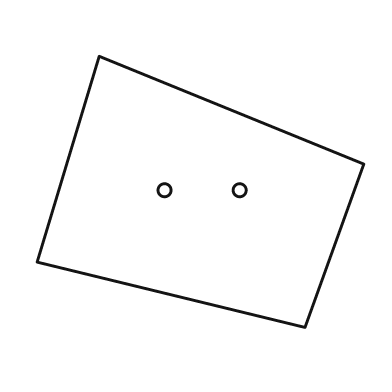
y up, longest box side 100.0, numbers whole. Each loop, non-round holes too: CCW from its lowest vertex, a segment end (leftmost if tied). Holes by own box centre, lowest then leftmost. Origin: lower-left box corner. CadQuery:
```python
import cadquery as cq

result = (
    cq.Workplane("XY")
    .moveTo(82.0, 0.0)
    .lineTo(100.0, 50.0)
    .lineTo(19.0, 83.0)
    .lineTo(0.0, 20.0)
    .close()
    .moveTo(39.0, 42.0)
    .circle(2.0)
    .moveTo(62.0, 42.0)
    .circle(2.0)
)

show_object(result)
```